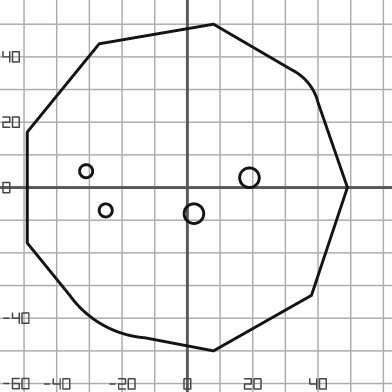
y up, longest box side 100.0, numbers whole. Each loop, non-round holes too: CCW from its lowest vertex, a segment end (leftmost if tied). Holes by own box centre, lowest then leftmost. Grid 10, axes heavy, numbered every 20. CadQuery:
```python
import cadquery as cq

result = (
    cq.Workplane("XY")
    .moveTo(8.0, -50.0)
    .lineTo(38.0, -33.0)
    .lineTo(49.0, 0.0)
    .lineTo(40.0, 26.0)
    .threePointArc((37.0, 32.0), (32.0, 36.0))
    .lineTo(8.0, 50.0)
    .lineTo(-27.0, 44.0)
    .lineTo(-49.0, 17.0)
    .lineTo(-49.0, -17.0)
    .lineTo(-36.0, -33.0)
    .threePointArc((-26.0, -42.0), (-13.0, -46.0))
    .close()
    .moveTo(2.0, -8.0)
    .circle(3.0)
    .moveTo(-25.0, -7.0)
    .circle(2.0)
    .moveTo(19.0, 3.0)
    .circle(3.0)
    .moveTo(-31.0, 5.0)
    .circle(2.0)
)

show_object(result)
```